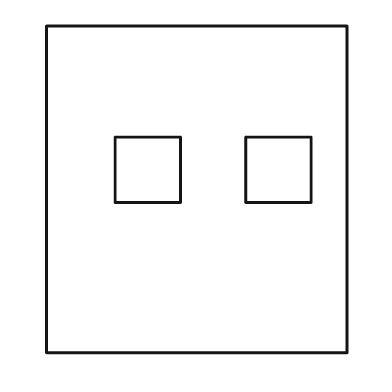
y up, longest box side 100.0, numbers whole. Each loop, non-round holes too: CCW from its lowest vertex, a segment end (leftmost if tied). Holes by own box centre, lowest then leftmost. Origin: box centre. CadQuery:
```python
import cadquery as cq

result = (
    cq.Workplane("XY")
    .moveTo(-46.0, -50.0)
    .lineTo(46.0, -50.0)
    .lineTo(46.0, 50.0)
    .lineTo(-46.0, 50.0)
    .close()
    .moveTo(-25.0, -4.0)
    .lineTo(-5.0, -4.0)
    .lineTo(-5.0, 16.0)
    .lineTo(-25.0, 16.0)
    .close()
    .moveTo(15.0, -4.0)
    .lineTo(35.0, -4.0)
    .lineTo(35.0, 16.0)
    .lineTo(15.0, 16.0)
    .close()
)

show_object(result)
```